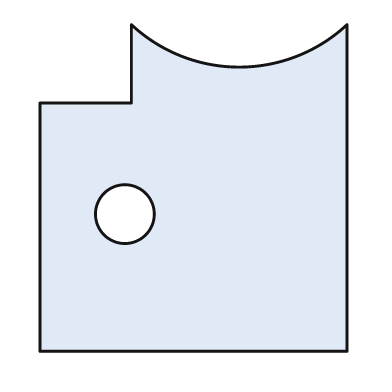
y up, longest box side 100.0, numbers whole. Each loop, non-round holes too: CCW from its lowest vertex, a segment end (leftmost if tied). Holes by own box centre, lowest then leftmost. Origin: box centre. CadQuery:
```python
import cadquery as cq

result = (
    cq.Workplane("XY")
    .moveTo(-47.0, -50.0)
    .lineTo(47.0, -50.0)
    .lineTo(47.0, 50.0)
    .threePointArc((14.0, 37.0), (-19.0, 50.0))
    .lineTo(-19.0, 26.0)
    .lineTo(-47.0, 26.0)
    .close()
    .moveTo(-21.0, -8.0)
    .circle(9.0)
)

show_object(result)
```